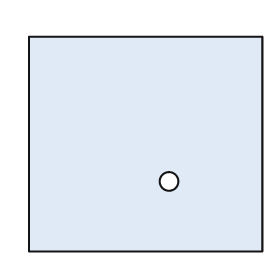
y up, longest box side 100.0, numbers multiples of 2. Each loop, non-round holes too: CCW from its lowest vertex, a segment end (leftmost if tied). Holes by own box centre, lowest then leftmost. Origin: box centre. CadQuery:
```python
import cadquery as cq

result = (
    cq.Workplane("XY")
    .moveTo(-50.0, -46.0)
    .lineTo(50.0, -46.0)
    .lineTo(50.0, 46.0)
    .lineTo(-50.0, 46.0)
    .close()
    .moveTo(10.0, -16.0)
    .circle(4.0)
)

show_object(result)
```